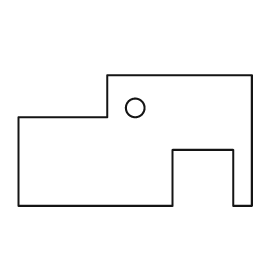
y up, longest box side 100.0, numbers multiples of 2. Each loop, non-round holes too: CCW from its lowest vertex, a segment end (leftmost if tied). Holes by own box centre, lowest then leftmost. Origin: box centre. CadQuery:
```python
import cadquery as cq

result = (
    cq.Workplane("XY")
    .moveTo(-50.0, -28.0)
    .lineTo(16.0, -28.0)
    .lineTo(16.0, -4.0)
    .lineTo(42.0, -4.0)
    .lineTo(42.0, -28.0)
    .lineTo(50.0, -28.0)
    .lineTo(50.0, 28.0)
    .lineTo(-12.0, 28.0)
    .lineTo(-12.0, 10.0)
    .lineTo(-50.0, 10.0)
    .close()
    .moveTo(0.0, 14.0)
    .circle(4.0)
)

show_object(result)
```